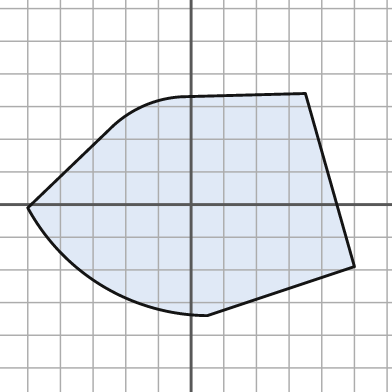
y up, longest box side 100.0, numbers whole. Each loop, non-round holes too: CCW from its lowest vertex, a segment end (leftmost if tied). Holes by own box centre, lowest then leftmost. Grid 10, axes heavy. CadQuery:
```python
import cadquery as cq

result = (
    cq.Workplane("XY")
    .moveTo(5.0, -34.0)
    .lineTo(50.0, -19.0)
    .lineTo(35.0, 34.0)
    .lineTo(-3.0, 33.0)
    .threePointArc((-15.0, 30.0), (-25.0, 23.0))
    .lineTo(-50.0, -1.0)
    .threePointArc((-27.0, -25.0), (5.0, -34.0))
    .close()
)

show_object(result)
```